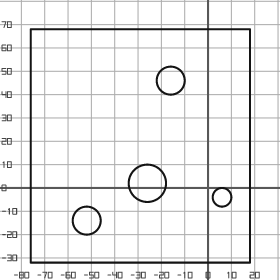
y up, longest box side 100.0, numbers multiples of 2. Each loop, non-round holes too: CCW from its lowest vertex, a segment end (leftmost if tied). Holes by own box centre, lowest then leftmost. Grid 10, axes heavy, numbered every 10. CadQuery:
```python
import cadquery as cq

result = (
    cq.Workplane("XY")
    .moveTo(-76.0, -32.0)
    .lineTo(18.0, -32.0)
    .lineTo(18.0, 68.0)
    .lineTo(-76.0, 68.0)
    .close()
    .moveTo(-52.0, -14.0)
    .circle(6.0)
    .moveTo(6.0, -4.0)
    .circle(4.0)
    .moveTo(-26.0, 2.0)
    .circle(8.0)
    .moveTo(-16.0, 46.0)
    .circle(6.0)
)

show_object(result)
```